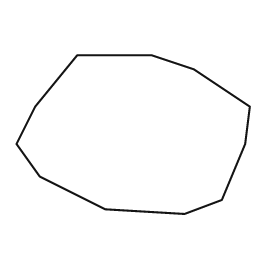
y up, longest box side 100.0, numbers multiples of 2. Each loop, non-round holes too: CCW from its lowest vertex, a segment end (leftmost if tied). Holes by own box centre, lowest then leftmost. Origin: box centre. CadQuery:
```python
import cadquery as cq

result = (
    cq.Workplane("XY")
    .moveTo(22.0, -34.0)
    .lineTo(38.0, -28.0)
    .lineTo(48.0, -4.0)
    .lineTo(50.0, 12.0)
    .lineTo(26.0, 28.0)
    .lineTo(8.0, 34.0)
    .lineTo(-24.0, 34.0)
    .lineTo(-42.0, 12.0)
    .lineTo(-50.0, -4.0)
    .lineTo(-40.0, -18.0)
    .lineTo(-12.0, -32.0)
    .close()
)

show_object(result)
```